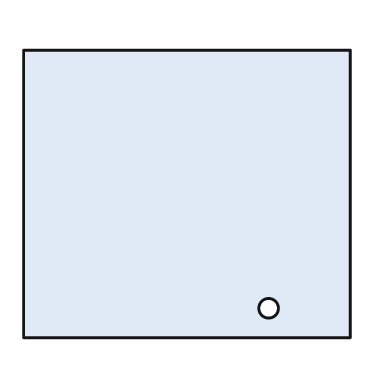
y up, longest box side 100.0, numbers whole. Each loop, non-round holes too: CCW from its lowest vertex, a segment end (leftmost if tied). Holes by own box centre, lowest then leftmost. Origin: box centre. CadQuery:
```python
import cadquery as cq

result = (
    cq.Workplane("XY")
    .moveTo(-50.0, -44.0)
    .lineTo(50.0, -44.0)
    .lineTo(50.0, 44.0)
    .lineTo(-50.0, 44.0)
    .close()
    .moveTo(25.0, -35.0)
    .circle(3.0)
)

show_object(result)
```